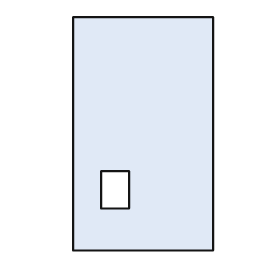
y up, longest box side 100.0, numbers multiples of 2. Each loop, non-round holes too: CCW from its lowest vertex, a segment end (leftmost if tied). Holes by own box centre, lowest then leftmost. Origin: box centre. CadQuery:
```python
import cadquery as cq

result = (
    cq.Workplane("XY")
    .moveTo(-30.0, -50.0)
    .lineTo(30.0, -50.0)
    .lineTo(30.0, 50.0)
    .lineTo(-30.0, 50.0)
    .close()
    .moveTo(-18.0, -32.0)
    .lineTo(-6.0, -32.0)
    .lineTo(-6.0, -16.0)
    .lineTo(-18.0, -16.0)
    .close()
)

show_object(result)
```